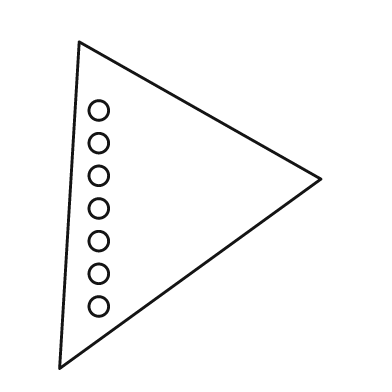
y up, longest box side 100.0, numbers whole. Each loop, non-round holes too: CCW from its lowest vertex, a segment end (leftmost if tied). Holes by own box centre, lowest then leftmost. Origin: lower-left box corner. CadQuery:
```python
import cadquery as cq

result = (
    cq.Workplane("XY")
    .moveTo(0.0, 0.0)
    .lineTo(80.0, 58.0)
    .lineTo(6.0, 100.0)
    .close()
    .moveTo(12.0, 19.0)
    .circle(3.0)
    .moveTo(12.0, 29.0)
    .circle(3.0)
    .moveTo(12.0, 39.0)
    .circle(3.0)
    .moveTo(12.0, 49.0)
    .circle(3.0)
    .moveTo(12.0, 59.0)
    .circle(3.0)
    .moveTo(12.0, 69.0)
    .circle(3.0)
    .moveTo(12.0, 79.0)
    .circle(3.0)
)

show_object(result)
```